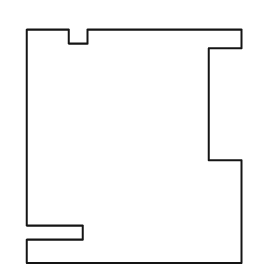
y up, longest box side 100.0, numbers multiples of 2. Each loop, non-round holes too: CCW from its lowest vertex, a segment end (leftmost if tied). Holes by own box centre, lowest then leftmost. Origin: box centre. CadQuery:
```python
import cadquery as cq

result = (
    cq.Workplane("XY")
    .moveTo(-46.0, -50.0)
    .lineTo(46.0, -50.0)
    .lineTo(46.0, -6.0)
    .lineTo(32.0, -6.0)
    .lineTo(32.0, 42.0)
    .lineTo(46.0, 42.0)
    .lineTo(46.0, 50.0)
    .lineTo(-20.0, 50.0)
    .lineTo(-20.0, 44.0)
    .lineTo(-28.0, 44.0)
    .lineTo(-28.0, 50.0)
    .lineTo(-46.0, 50.0)
    .lineTo(-46.0, -34.0)
    .lineTo(-22.0, -34.0)
    .lineTo(-22.0, -40.0)
    .lineTo(-46.0, -40.0)
    .close()
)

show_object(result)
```